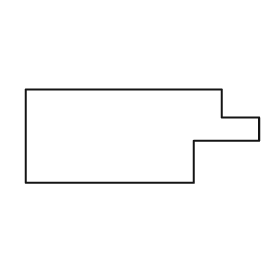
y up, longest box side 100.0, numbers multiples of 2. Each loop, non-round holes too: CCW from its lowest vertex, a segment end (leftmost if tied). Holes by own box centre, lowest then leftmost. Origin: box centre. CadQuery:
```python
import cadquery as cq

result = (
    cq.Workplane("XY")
    .moveTo(-50.0, -20.0)
    .lineTo(22.0, -20.0)
    .lineTo(22.0, -2.0)
    .lineTo(50.0, -2.0)
    .lineTo(50.0, 8.0)
    .lineTo(34.0, 8.0)
    .lineTo(34.0, 20.0)
    .lineTo(-50.0, 20.0)
    .close()
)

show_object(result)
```